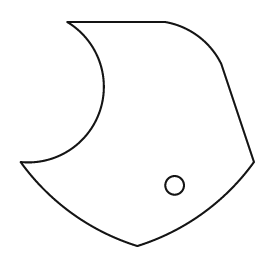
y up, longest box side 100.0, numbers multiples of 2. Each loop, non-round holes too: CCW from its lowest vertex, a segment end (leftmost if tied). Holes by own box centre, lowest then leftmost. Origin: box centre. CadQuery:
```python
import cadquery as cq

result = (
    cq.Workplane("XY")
    .moveTo(0.0, -48.0)
    .threePointArc((28.0, -34.0), (50.0, -12.0))
    .lineTo(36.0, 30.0)
    .threePointArc((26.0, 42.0), (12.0, 48.0))
    .lineTo(-30.0, 48.0)
    .threePointArc((-16.0, 10.0), (-50.0, -12.0))
    .threePointArc((-28.0, -34.0), (0.0, -48.0))
    .close()
    .moveTo(16.0, -22.0)
    .circle(4.0)
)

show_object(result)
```